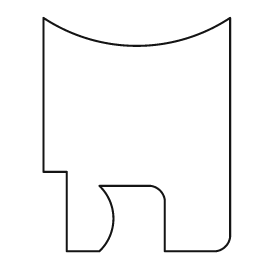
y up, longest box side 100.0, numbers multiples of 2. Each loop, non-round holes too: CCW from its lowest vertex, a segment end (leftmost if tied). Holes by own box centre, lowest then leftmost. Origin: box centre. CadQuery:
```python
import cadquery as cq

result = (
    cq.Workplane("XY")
    .moveTo(-30.0, -50.0)
    .lineTo(-16.0, -50.0)
    .threePointArc((-10.0, -36.0), (-16.0, -22.0))
    .lineTo(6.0, -22.0)
    .threePointArc((10.0, -24.0), (12.0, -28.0))
    .lineTo(12.0, -50.0)
    .lineTo(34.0, -50.0)
    .threePointArc((38.0, -48.0), (40.0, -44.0))
    .lineTo(40.0, 50.0)
    .threePointArc((0.0, 38.0), (-40.0, 50.0))
    .lineTo(-40.0, -16.0)
    .lineTo(-30.0, -16.0)
    .close()
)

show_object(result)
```